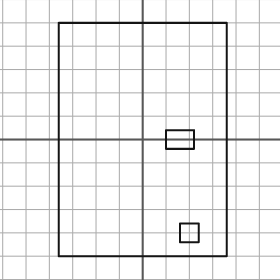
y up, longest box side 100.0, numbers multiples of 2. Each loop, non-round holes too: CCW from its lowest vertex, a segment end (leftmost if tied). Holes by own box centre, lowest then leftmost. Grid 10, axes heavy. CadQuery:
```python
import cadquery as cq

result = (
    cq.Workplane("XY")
    .moveTo(-36.0, -50.0)
    .lineTo(36.0, -50.0)
    .lineTo(36.0, 50.0)
    .lineTo(-36.0, 50.0)
    .close()
    .moveTo(16.0, -44.0)
    .lineTo(24.0, -44.0)
    .lineTo(24.0, -36.0)
    .lineTo(16.0, -36.0)
    .close()
    .moveTo(10.0, -4.0)
    .lineTo(22.0, -4.0)
    .lineTo(22.0, 4.0)
    .lineTo(10.0, 4.0)
    .close()
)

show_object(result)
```